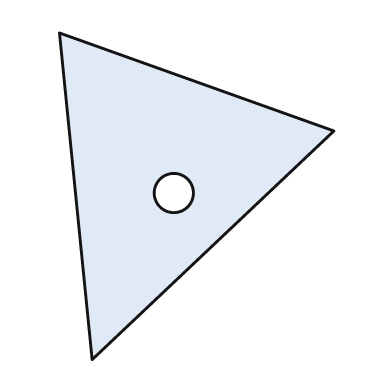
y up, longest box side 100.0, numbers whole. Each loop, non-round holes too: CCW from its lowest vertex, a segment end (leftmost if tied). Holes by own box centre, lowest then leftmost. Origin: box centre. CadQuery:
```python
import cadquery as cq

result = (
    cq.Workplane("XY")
    .moveTo(-32.0, -50.0)
    .lineTo(42.0, 20.0)
    .lineTo(-42.0, 50.0)
    .close()
    .moveTo(-7.0, 1.0)
    .circle(6.0)
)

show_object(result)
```